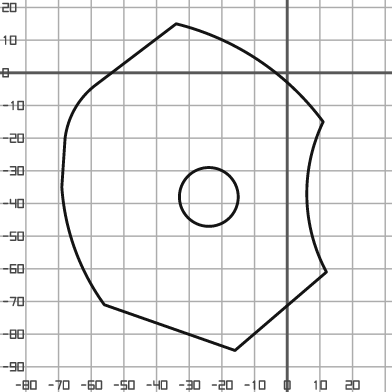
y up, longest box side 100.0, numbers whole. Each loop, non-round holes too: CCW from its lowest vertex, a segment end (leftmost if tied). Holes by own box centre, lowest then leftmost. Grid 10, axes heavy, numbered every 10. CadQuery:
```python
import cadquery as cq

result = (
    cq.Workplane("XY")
    .moveTo(-16.0, -85.0)
    .lineTo(12.0, -61.0)
    .threePointArc((6.0, -38.0), (11.0, -15.0))
    .threePointArc((-9.0, 4.0), (-34.0, 15.0))
    .lineTo(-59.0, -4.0)
    .threePointArc((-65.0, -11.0), (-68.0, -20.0))
    .lineTo(-69.0, -35.0)
    .threePointArc((-65.0, -54.0), (-56.0, -71.0))
    .close()
    .moveTo(-24.0, -38.0)
    .circle(9.0)
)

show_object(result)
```